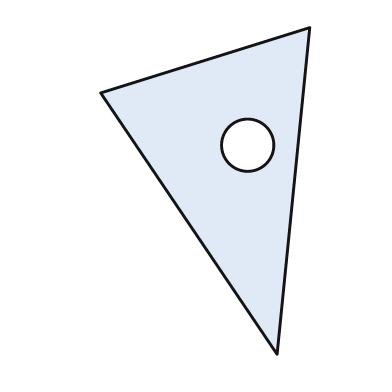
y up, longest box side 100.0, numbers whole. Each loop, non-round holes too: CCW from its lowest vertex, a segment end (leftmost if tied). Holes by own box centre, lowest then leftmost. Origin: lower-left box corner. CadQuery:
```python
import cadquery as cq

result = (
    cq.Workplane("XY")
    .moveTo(54.0, 0.0)
    .lineTo(64.0, 100.0)
    .lineTo(0.0, 80.0)
    .close()
    .moveTo(45.0, 64.0)
    .circle(8.0)
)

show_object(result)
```